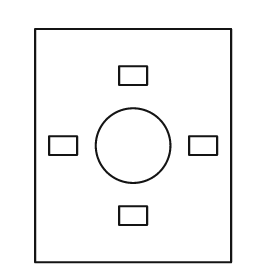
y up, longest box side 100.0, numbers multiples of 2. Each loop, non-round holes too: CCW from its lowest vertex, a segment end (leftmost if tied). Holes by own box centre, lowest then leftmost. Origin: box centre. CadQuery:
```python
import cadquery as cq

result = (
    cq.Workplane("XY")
    .moveTo(-42.0, -50.0)
    .lineTo(42.0, -50.0)
    .lineTo(42.0, 50.0)
    .lineTo(-42.0, 50.0)
    .close()
    .moveTo(-6.0, -34.0)
    .lineTo(6.0, -34.0)
    .lineTo(6.0, -26.0)
    .lineTo(-6.0, -26.0)
    .close()
    .moveTo(-36.0, -4.0)
    .lineTo(-24.0, -4.0)
    .lineTo(-24.0, 4.0)
    .lineTo(-36.0, 4.0)
    .close()
    .moveTo(0.0, 0.0)
    .circle(16.0)
    .moveTo(24.0, -4.0)
    .lineTo(36.0, -4.0)
    .lineTo(36.0, 4.0)
    .lineTo(24.0, 4.0)
    .close()
    .moveTo(-6.0, 26.0)
    .lineTo(6.0, 26.0)
    .lineTo(6.0, 34.0)
    .lineTo(-6.0, 34.0)
    .close()
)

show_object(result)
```